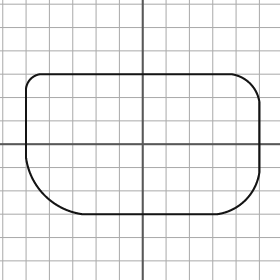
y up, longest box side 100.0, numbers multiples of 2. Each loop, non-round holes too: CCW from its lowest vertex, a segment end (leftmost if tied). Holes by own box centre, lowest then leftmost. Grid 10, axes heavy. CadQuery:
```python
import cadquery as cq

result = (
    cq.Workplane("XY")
    .moveTo(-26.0, -30.0)
    .lineTo(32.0, -30.0)
    .threePointArc((44.0, -24.0), (50.0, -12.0))
    .lineTo(50.0, 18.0)
    .threePointArc((46.0, 26.0), (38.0, 30.0))
    .lineTo(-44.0, 30.0)
    .threePointArc((-48.0, 28.0), (-50.0, 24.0))
    .lineTo(-50.0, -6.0)
    .threePointArc((-42.0, -22.0), (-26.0, -30.0))
    .close()
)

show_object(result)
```